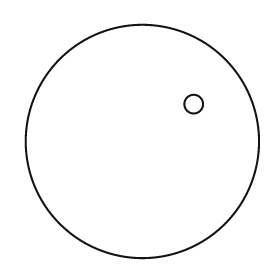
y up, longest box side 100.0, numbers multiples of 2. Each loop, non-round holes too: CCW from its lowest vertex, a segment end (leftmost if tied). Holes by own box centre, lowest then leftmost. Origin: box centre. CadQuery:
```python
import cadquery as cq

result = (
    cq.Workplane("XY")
    .moveTo(0.0, 0.0)
    .circle(50.0)
    .moveTo(22.0, 16.0)
    .circle(4.0)
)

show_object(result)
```